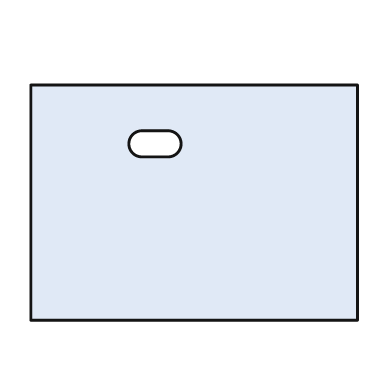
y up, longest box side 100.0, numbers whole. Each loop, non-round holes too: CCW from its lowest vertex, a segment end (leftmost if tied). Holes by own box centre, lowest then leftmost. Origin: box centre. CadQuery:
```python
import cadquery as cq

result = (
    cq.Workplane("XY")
    .moveTo(-50.0, -36.0)
    .lineTo(50.0, -36.0)
    .lineTo(50.0, 36.0)
    .lineTo(-50.0, 36.0)
    .close()
    .moveTo(-16.0, 14.0)
    .lineTo(-8.0, 14.0)
    .threePointArc((-4.0, 18.0), (-8.0, 22.0))
    .lineTo(-16.0, 22.0)
    .threePointArc((-20.0, 18.0), (-16.0, 14.0))
    .close()
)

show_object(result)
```